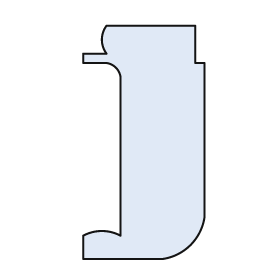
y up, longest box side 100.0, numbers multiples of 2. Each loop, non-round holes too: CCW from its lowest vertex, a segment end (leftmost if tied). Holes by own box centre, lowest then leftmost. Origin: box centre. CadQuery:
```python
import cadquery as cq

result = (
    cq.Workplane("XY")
    .moveTo(-26.0, -50.0)
    .lineTo(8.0, -50.0)
    .threePointArc((20.0, -44.0), (26.0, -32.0))
    .lineTo(26.0, 34.0)
    .lineTo(22.0, 34.0)
    .lineTo(22.0, 50.0)
    .lineTo(-16.0, 50.0)
    .threePointArc((-18.0, 44.0), (-16.0, 38.0))
    .lineTo(-26.0, 38.0)
    .lineTo(-26.0, 34.0)
    .lineTo(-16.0, 34.0)
    .threePointArc((-12.0, 32.0), (-10.0, 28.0))
    .lineTo(-10.0, -40.0)
    .threePointArc((-18.0, -38.0), (-26.0, -40.0))
    .close()
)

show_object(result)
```